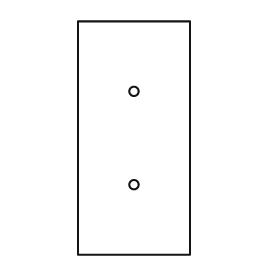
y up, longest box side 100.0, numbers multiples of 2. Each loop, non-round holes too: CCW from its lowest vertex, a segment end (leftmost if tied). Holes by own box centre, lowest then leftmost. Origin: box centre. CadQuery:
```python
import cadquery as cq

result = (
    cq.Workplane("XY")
    .moveTo(-24.0, -50.0)
    .lineTo(24.0, -50.0)
    .lineTo(24.0, 50.0)
    .lineTo(-24.0, 50.0)
    .close()
    .moveTo(0.0, -20.0)
    .circle(2.0)
    .moveTo(0.0, 20.0)
    .circle(2.0)
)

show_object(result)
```